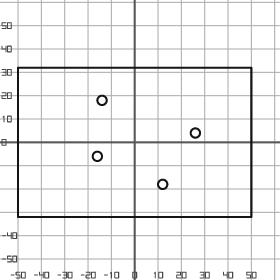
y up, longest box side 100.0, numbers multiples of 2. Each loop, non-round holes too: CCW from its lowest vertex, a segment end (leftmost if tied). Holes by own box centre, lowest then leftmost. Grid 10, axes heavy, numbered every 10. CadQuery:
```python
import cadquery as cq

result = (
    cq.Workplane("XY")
    .moveTo(-50.0, -32.0)
    .lineTo(50.0, -32.0)
    .lineTo(50.0, 32.0)
    .lineTo(-50.0, 32.0)
    .close()
    .moveTo(12.0, -18.0)
    .circle(2.0)
    .moveTo(-16.0, -6.0)
    .circle(2.0)
    .moveTo(26.0, 4.0)
    .circle(2.0)
    .moveTo(-14.0, 18.0)
    .circle(2.0)
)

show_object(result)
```